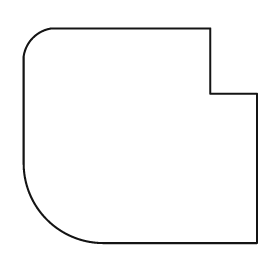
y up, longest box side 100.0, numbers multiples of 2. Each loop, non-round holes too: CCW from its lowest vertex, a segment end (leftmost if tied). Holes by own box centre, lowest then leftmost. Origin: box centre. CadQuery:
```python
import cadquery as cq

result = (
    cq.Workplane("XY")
    .moveTo(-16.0, -46.0)
    .lineTo(50.0, -46.0)
    .lineTo(50.0, 18.0)
    .lineTo(30.0, 18.0)
    .lineTo(30.0, 46.0)
    .lineTo(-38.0, 46.0)
    .threePointArc((-46.0, 42.0), (-50.0, 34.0))
    .lineTo(-50.0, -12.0)
    .threePointArc((-40.0, -36.0), (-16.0, -46.0))
    .close()
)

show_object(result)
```